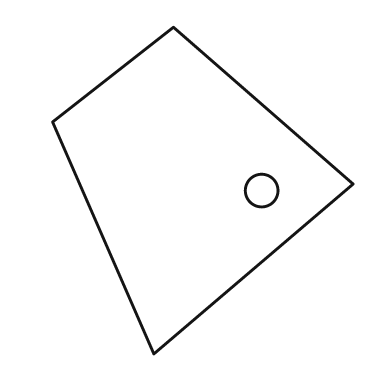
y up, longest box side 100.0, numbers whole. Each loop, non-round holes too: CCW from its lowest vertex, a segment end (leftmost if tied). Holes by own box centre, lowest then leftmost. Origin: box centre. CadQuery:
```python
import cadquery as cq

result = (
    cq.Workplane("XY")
    .moveTo(-15.0, -50.0)
    .lineTo(46.0, 2.0)
    .lineTo(-9.0, 50.0)
    .lineTo(-46.0, 21.0)
    .close()
    .moveTo(18.0, 0.0)
    .circle(5.0)
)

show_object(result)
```